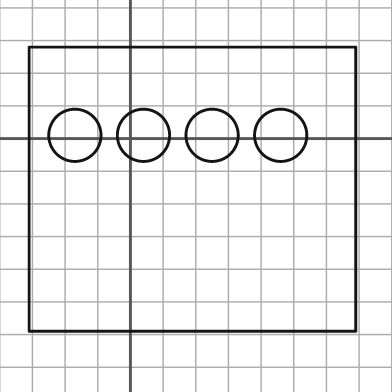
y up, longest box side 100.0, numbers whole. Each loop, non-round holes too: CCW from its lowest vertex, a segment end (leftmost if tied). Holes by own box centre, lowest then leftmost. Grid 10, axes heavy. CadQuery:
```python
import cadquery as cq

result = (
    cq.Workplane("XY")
    .moveTo(-31.0, -59.0)
    .lineTo(69.0, -59.0)
    .lineTo(69.0, 28.0)
    .lineTo(-31.0, 28.0)
    .close()
    .moveTo(-17.0, 1.0)
    .circle(8.0)
    .moveTo(4.0, 1.0)
    .circle(8.0)
    .moveTo(25.0, 1.0)
    .circle(8.0)
    .moveTo(46.0, 1.0)
    .circle(8.0)
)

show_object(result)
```